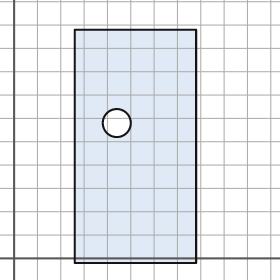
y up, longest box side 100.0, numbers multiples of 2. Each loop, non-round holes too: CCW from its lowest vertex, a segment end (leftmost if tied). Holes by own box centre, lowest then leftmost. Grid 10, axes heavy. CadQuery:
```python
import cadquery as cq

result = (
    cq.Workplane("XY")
    .moveTo(26.0, -2.0)
    .lineTo(78.0, -2.0)
    .lineTo(78.0, 98.0)
    .lineTo(26.0, 98.0)
    .close()
    .moveTo(44.0, 58.0)
    .circle(6.0)
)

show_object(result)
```